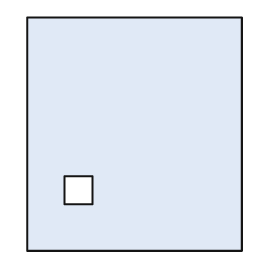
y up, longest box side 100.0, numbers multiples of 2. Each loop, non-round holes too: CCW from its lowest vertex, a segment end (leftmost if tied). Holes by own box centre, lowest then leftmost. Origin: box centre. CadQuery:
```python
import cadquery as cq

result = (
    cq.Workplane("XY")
    .moveTo(-46.0, -50.0)
    .lineTo(46.0, -50.0)
    .lineTo(46.0, 50.0)
    .lineTo(-46.0, 50.0)
    .close()
    .moveTo(-30.0, -30.0)
    .lineTo(-18.0, -30.0)
    .lineTo(-18.0, -18.0)
    .lineTo(-30.0, -18.0)
    .close()
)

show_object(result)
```